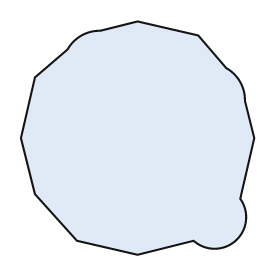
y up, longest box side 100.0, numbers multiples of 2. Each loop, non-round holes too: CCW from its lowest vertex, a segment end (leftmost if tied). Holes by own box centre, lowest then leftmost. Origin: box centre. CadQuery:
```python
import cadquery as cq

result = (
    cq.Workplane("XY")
    .moveTo(0.0, -50.0)
    .lineTo(24.0, -44.0)
    .threePointArc((42.0, -44.0), (44.0, -26.0))
    .lineTo(50.0, 0.0)
    .lineTo(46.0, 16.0)
    .threePointArc((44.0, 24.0), (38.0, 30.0))
    .lineTo(26.0, 44.0)
    .lineTo(0.0, 50.0)
    .lineTo(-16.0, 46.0)
    .threePointArc((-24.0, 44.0), (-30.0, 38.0))
    .lineTo(-44.0, 26.0)
    .lineTo(-50.0, 0.0)
    .lineTo(-44.0, -24.0)
    .lineTo(-26.0, -44.0)
    .close()
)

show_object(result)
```